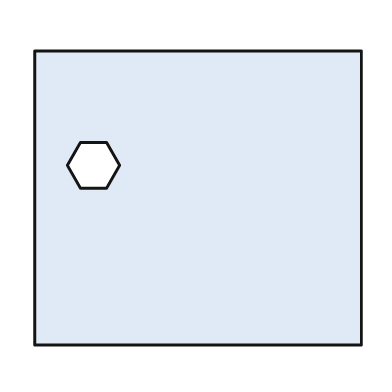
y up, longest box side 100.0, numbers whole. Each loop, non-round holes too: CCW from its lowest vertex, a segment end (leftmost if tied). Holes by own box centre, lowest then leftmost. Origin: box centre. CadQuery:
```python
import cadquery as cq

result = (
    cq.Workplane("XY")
    .moveTo(-50.0, -45.0)
    .lineTo(50.0, -45.0)
    .lineTo(50.0, 45.0)
    .lineTo(-50.0, 45.0)
    .close()
    .moveTo(-36.0, 3.0)
    .lineTo(-28.0, 3.0)
    .lineTo(-24.0, 10.0)
    .lineTo(-28.0, 17.0)
    .lineTo(-36.0, 17.0)
    .lineTo(-40.0, 10.0)
    .close()
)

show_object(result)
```